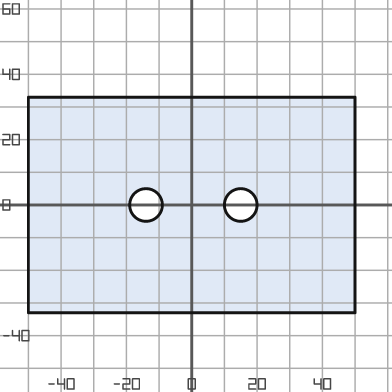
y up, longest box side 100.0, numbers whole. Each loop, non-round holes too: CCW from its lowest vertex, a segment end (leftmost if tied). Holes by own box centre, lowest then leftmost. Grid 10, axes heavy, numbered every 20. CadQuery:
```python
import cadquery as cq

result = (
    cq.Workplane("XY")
    .moveTo(-50.0, -33.0)
    .lineTo(50.0, -33.0)
    .lineTo(50.0, 33.0)
    .lineTo(-50.0, 33.0)
    .close()
    .moveTo(-14.0, 0.0)
    .circle(5.0)
    .moveTo(15.0, 0.0)
    .circle(5.0)
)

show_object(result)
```